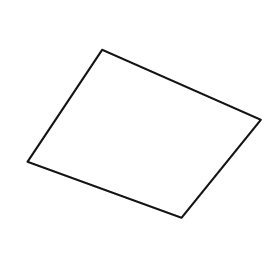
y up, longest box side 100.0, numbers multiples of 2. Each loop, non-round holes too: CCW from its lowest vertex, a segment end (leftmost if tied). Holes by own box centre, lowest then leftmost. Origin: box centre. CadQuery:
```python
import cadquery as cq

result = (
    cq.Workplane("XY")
    .moveTo(16.0, -36.0)
    .lineTo(50.0, 6.0)
    .lineTo(-18.0, 36.0)
    .lineTo(-50.0, -12.0)
    .close()
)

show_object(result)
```